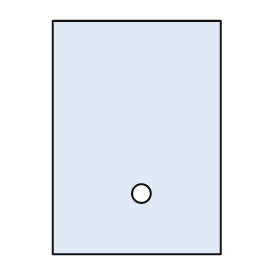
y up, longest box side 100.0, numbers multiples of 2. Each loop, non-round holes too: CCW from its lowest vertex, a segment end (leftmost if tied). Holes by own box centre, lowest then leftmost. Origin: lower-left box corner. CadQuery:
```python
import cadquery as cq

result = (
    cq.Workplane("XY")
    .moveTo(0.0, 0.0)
    .lineTo(72.0, 0.0)
    .lineTo(72.0, 100.0)
    .lineTo(0.0, 100.0)
    .close()
    .moveTo(38.0, 26.0)
    .circle(4.0)
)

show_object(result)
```